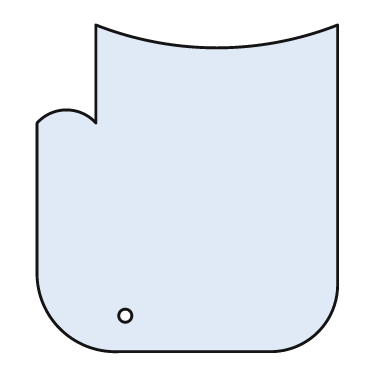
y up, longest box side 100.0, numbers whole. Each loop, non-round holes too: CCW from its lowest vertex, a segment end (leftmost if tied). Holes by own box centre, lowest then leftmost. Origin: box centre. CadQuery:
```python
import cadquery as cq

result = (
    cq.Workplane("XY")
    .moveTo(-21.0, -50.0)
    .lineTo(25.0, -50.0)
    .threePointArc((40.0, -44.0), (46.0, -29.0))
    .lineTo(46.0, 50.0)
    .threePointArc((9.0, 43.0), (-28.0, 50.0))
    .lineTo(-28.0, 20.0)
    .threePointArc((-37.0, 24.0), (-46.0, 20.0))
    .lineTo(-46.0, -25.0)
    .threePointArc((-39.0, -43.0), (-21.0, -50.0))
    .close()
    .moveTo(-19.0, -39.0)
    .circle(2.0)
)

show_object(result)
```